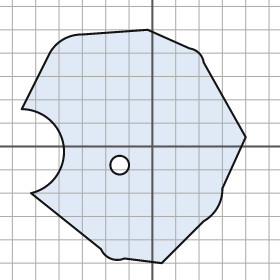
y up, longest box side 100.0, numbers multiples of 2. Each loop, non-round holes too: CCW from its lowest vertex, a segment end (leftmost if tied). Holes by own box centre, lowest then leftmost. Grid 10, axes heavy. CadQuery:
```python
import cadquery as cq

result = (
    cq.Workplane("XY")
    .moveTo(4.0, -50.0)
    .lineTo(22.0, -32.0)
    .threePointArc((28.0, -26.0), (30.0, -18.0))
    .lineTo(40.0, 4.0)
    .lineTo(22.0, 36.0)
    .threePointArc((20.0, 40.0), (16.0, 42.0))
    .lineTo(-2.0, 50.0)
    .lineTo(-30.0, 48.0)
    .threePointArc((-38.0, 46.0), (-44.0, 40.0))
    .lineTo(-56.0, 16.0)
    .threePointArc((-38.0, 0.0), (-52.0, -20.0))
    .lineTo(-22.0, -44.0)
    .threePointArc((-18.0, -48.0), (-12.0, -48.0))
    .close()
    .moveTo(-14.0, -8.0)
    .circle(4.0)
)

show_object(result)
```